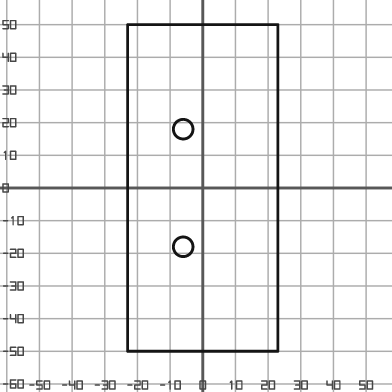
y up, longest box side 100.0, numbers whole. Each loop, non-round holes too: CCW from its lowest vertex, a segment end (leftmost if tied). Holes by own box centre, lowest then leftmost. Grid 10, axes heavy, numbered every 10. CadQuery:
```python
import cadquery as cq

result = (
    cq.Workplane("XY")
    .moveTo(-23.0, -50.0)
    .lineTo(23.0, -50.0)
    .lineTo(23.0, 50.0)
    .lineTo(-23.0, 50.0)
    .close()
    .moveTo(-6.0, -18.0)
    .circle(3.0)
    .moveTo(-6.0, 18.0)
    .circle(3.0)
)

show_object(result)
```